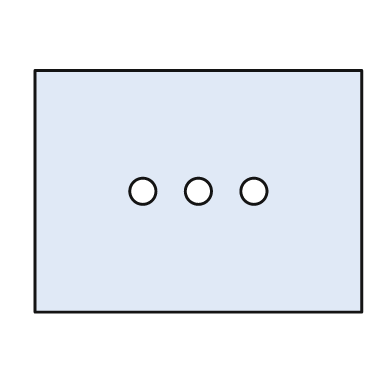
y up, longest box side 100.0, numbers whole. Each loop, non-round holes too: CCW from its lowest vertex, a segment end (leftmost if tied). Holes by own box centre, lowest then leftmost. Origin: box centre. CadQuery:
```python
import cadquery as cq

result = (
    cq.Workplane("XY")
    .moveTo(-50.0, -37.0)
    .lineTo(50.0, -37.0)
    .lineTo(50.0, 37.0)
    .lineTo(-50.0, 37.0)
    .close()
    .moveTo(-17.0, 0.0)
    .circle(4.0)
    .moveTo(0.0, 0.0)
    .circle(4.0)
    .moveTo(17.0, 0.0)
    .circle(4.0)
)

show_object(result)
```